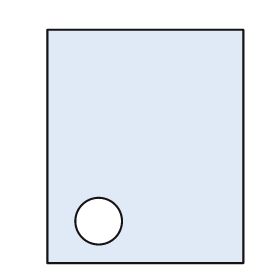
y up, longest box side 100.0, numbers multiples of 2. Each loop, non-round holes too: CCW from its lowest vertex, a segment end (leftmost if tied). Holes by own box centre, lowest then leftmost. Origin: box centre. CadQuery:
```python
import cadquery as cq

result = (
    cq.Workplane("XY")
    .moveTo(-42.0, -50.0)
    .lineTo(42.0, -50.0)
    .lineTo(42.0, 50.0)
    .lineTo(-42.0, 50.0)
    .close()
    .moveTo(-20.0, -32.0)
    .circle(10.0)
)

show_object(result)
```